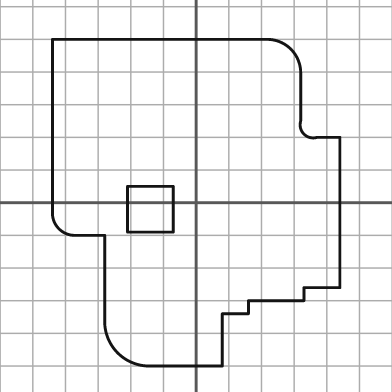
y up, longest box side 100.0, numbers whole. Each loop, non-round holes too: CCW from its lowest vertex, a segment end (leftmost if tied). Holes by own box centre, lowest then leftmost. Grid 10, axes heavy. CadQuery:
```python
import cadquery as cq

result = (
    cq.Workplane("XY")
    .moveTo(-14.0, -50.0)
    .lineTo(8.0, -50.0)
    .lineTo(8.0, -34.0)
    .lineTo(16.0, -34.0)
    .lineTo(16.0, -30.0)
    .lineTo(33.0, -30.0)
    .lineTo(33.0, -26.0)
    .lineTo(44.0, -26.0)
    .lineTo(44.0, 20.0)
    .lineTo(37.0, 20.0)
    .threePointArc((33.0, 21.0), (32.0, 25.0))
    .lineTo(32.0, 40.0)
    .threePointArc((29.0, 47.0), (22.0, 50.0))
    .lineTo(-44.0, 50.0)
    .lineTo(-44.0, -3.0)
    .threePointArc((-42.0, -8.0), (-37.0, -10.0))
    .lineTo(-28.0, -10.0)
    .lineTo(-28.0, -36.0)
    .threePointArc((-24.0, -46.0), (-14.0, -50.0))
    .close()
    .moveTo(-21.0, -9.0)
    .lineTo(-7.0, -9.0)
    .lineTo(-7.0, 5.0)
    .lineTo(-21.0, 5.0)
    .close()
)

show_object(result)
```